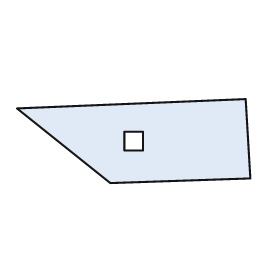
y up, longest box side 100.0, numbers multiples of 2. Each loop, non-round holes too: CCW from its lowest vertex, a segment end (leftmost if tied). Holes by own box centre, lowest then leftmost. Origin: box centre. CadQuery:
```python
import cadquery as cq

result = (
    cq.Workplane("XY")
    .moveTo(-10.0, -18.0)
    .lineTo(50.0, -16.0)
    .lineTo(48.0, 18.0)
    .lineTo(-50.0, 14.0)
    .close()
    .moveTo(-4.0, -4.0)
    .lineTo(4.0, -4.0)
    .lineTo(4.0, 4.0)
    .lineTo(-4.0, 4.0)
    .close()
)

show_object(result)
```